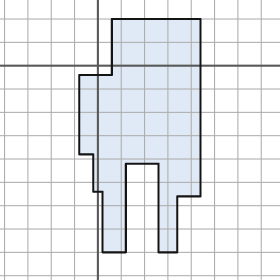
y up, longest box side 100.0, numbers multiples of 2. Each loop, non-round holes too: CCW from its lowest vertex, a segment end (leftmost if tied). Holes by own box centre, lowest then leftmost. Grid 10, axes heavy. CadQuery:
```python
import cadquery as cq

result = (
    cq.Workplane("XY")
    .moveTo(2.0, -80.0)
    .lineTo(12.0, -80.0)
    .lineTo(12.0, -42.0)
    .lineTo(26.0, -42.0)
    .lineTo(26.0, -80.0)
    .lineTo(34.0, -80.0)
    .lineTo(34.0, -56.0)
    .lineTo(44.0, -56.0)
    .lineTo(44.0, 20.0)
    .lineTo(6.0, 20.0)
    .lineTo(6.0, -4.0)
    .lineTo(-8.0, -4.0)
    .lineTo(-8.0, -38.0)
    .lineTo(-2.0, -38.0)
    .lineTo(-2.0, -54.0)
    .lineTo(2.0, -54.0)
    .close()
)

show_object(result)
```